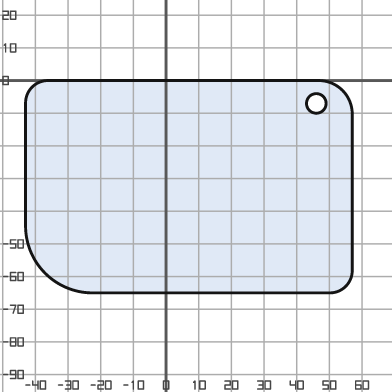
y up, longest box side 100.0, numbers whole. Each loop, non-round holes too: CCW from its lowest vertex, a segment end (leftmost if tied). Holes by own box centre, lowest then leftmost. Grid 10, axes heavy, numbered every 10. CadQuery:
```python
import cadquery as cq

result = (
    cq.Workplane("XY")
    .moveTo(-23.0, -65.0)
    .lineTo(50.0, -65.0)
    .threePointArc((55.0, -63.0), (57.0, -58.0))
    .lineTo(57.0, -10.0)
    .threePointArc((54.0, -3.0), (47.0, 0.0))
    .lineTo(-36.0, 0.0)
    .threePointArc((-41.0, -2.0), (-43.0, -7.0))
    .lineTo(-43.0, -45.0)
    .threePointArc((-37.0, -59.0), (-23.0, -65.0))
    .close()
    .moveTo(46.0, -7.0)
    .circle(3.0)
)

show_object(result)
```